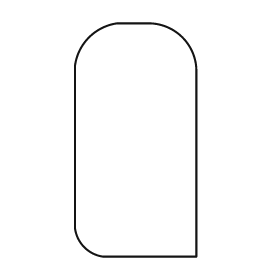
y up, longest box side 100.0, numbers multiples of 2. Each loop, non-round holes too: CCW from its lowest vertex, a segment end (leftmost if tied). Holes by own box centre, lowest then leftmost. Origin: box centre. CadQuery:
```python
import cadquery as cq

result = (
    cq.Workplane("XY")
    .moveTo(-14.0, -50.0)
    .lineTo(26.0, -50.0)
    .lineTo(26.0, 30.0)
    .threePointArc((20.0, 44.0), (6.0, 50.0))
    .lineTo(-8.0, 50.0)
    .threePointArc((-20.0, 44.0), (-26.0, 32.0))
    .lineTo(-26.0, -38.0)
    .threePointArc((-22.0, -46.0), (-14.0, -50.0))
    .close()
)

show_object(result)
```